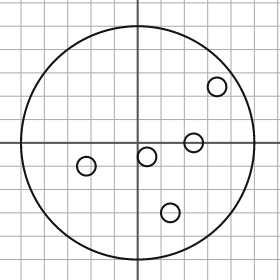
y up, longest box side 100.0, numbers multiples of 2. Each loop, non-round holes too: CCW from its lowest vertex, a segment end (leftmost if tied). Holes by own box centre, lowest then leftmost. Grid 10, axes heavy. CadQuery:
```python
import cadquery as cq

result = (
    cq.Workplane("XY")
    .moveTo(0.0, 0.0)
    .circle(50.0)
    .moveTo(14.0, -30.0)
    .circle(4.0)
    .moveTo(-22.0, -10.0)
    .circle(4.0)
    .moveTo(4.0, -6.0)
    .circle(4.0)
    .moveTo(24.0, 0.0)
    .circle(4.0)
    .moveTo(34.0, 24.0)
    .circle(4.0)
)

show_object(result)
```